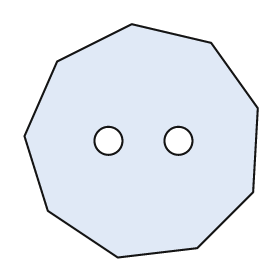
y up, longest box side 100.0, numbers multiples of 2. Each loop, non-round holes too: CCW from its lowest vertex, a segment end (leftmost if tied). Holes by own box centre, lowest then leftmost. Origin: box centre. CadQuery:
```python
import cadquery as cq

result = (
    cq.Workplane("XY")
    .moveTo(-10.0, -50.0)
    .lineTo(24.0, -46.0)
    .lineTo(48.0, -22.0)
    .lineTo(50.0, 14.0)
    .lineTo(30.0, 42.0)
    .lineTo(-4.0, 50.0)
    .lineTo(-36.0, 34.0)
    .lineTo(-50.0, 2.0)
    .lineTo(-40.0, -30.0)
    .close()
    .moveTo(-14.0, 0.0)
    .circle(6.0)
    .moveTo(16.0, 0.0)
    .circle(6.0)
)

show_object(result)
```